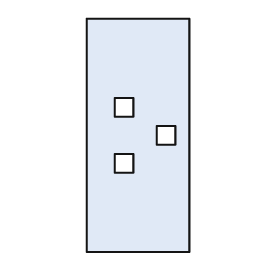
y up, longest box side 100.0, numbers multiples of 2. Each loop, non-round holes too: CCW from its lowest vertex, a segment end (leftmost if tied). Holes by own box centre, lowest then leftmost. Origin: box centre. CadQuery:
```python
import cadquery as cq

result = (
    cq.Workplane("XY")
    .moveTo(-22.0, -50.0)
    .lineTo(22.0, -50.0)
    .lineTo(22.0, 50.0)
    .lineTo(-22.0, 50.0)
    .close()
    .moveTo(-10.0, -16.0)
    .lineTo(-2.0, -16.0)
    .lineTo(-2.0, -8.0)
    .lineTo(-10.0, -8.0)
    .close()
    .moveTo(8.0, -4.0)
    .lineTo(16.0, -4.0)
    .lineTo(16.0, 4.0)
    .lineTo(8.0, 4.0)
    .close()
    .moveTo(-10.0, 8.0)
    .lineTo(-2.0, 8.0)
    .lineTo(-2.0, 16.0)
    .lineTo(-10.0, 16.0)
    .close()
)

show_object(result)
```